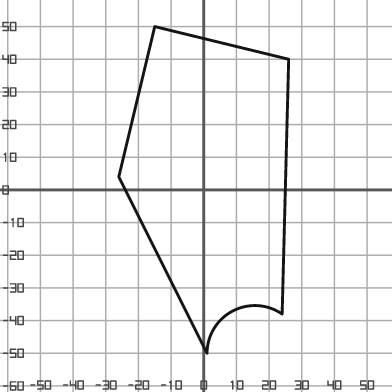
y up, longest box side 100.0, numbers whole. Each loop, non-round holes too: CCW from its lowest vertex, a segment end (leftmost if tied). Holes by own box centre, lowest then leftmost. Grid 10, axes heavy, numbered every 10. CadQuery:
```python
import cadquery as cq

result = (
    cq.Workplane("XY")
    .moveTo(1.0, -50.0)
    .threePointArc((9.0, -37.0), (24.0, -38.0))
    .lineTo(26.0, 40.0)
    .lineTo(-15.0, 50.0)
    .lineTo(-26.0, 4.0)
    .close()
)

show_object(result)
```